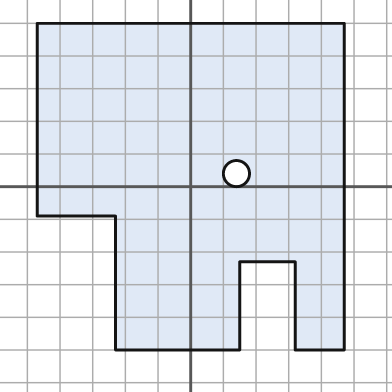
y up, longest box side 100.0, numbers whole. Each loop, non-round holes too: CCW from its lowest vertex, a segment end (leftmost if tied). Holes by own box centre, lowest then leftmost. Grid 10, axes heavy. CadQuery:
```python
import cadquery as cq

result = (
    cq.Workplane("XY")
    .moveTo(-23.0, -50.0)
    .lineTo(15.0, -50.0)
    .lineTo(15.0, -23.0)
    .lineTo(32.0, -23.0)
    .lineTo(32.0, -50.0)
    .lineTo(47.0, -50.0)
    .lineTo(47.0, 50.0)
    .lineTo(-47.0, 50.0)
    .lineTo(-47.0, -9.0)
    .lineTo(-23.0, -9.0)
    .close()
    .moveTo(14.0, 4.0)
    .circle(4.0)
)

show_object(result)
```